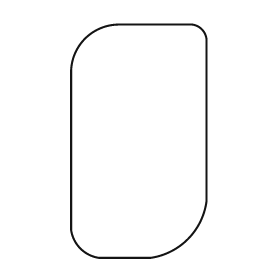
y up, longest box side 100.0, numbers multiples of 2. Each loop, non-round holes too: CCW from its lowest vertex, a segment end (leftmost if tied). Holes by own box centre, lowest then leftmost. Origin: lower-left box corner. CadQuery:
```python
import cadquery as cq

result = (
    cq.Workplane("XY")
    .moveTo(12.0, 0.0)
    .lineTo(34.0, 0.0)
    .threePointArc((50.0, 8.0), (58.0, 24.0))
    .lineTo(58.0, 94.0)
    .threePointArc((56.0, 98.0), (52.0, 100.0))
    .lineTo(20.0, 100.0)
    .threePointArc((6.0, 94.0), (0.0, 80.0))
    .lineTo(0.0, 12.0)
    .threePointArc((4.0, 4.0), (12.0, 0.0))
    .close()
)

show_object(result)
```